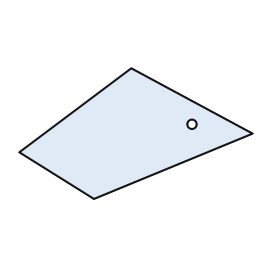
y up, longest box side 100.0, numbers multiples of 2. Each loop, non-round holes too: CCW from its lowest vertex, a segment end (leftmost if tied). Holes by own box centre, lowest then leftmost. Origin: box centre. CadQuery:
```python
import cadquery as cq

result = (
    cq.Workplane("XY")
    .moveTo(-18.0, -28.0)
    .lineTo(50.0, 0.0)
    .lineTo(-2.0, 28.0)
    .lineTo(-50.0, -8.0)
    .close()
    .moveTo(24.0, 4.0)
    .circle(2.0)
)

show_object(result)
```